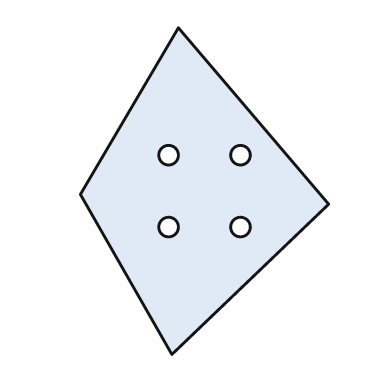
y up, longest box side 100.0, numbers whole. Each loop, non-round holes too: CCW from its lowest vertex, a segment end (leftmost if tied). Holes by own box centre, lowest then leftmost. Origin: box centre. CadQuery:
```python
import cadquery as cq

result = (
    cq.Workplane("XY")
    .moveTo(-10.0, -50.0)
    .lineTo(38.0, -4.0)
    .lineTo(-8.0, 50.0)
    .lineTo(-38.0, -1.0)
    .close()
    .moveTo(-11.0, -11.0)
    .circle(3.0)
    .moveTo(11.0, -11.0)
    .circle(3.0)
    .moveTo(-11.0, 11.0)
    .circle(3.0)
    .moveTo(11.0, 11.0)
    .circle(3.0)
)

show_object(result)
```